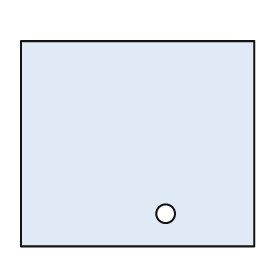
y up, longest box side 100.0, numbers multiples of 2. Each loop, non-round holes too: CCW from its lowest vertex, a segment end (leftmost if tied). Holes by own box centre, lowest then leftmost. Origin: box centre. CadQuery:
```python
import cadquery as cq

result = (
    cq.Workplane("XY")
    .moveTo(-50.0, -44.0)
    .lineTo(50.0, -44.0)
    .lineTo(50.0, 44.0)
    .lineTo(-50.0, 44.0)
    .close()
    .moveTo(12.0, -30.0)
    .circle(4.0)
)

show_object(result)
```